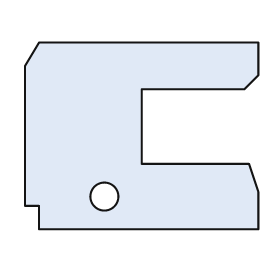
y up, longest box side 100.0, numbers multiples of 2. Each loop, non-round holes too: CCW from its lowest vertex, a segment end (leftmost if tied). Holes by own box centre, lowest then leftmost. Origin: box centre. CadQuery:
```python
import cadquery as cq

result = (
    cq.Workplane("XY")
    .moveTo(-44.0, -40.0)
    .lineTo(50.0, -40.0)
    .lineTo(50.0, -24.0)
    .lineTo(46.0, -12.0)
    .lineTo(0.0, -12.0)
    .lineTo(0.0, 20.0)
    .lineTo(44.0, 20.0)
    .lineTo(50.0, 26.0)
    .lineTo(50.0, 40.0)
    .lineTo(-44.0, 40.0)
    .lineTo(-50.0, 30.0)
    .lineTo(-50.0, -30.0)
    .lineTo(-44.0, -30.0)
    .close()
    .moveTo(-16.0, -26.0)
    .circle(6.0)
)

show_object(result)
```